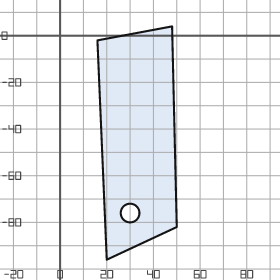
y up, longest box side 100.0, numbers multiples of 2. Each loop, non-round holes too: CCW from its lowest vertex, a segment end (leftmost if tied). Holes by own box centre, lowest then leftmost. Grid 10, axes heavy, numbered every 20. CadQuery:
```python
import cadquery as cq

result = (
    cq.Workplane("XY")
    .moveTo(20.0, -96.0)
    .lineTo(50.0, -82.0)
    .lineTo(48.0, 4.0)
    .lineTo(16.0, -2.0)
    .close()
    .moveTo(30.0, -76.0)
    .circle(4.0)
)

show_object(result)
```